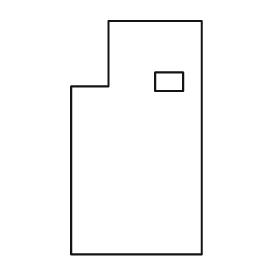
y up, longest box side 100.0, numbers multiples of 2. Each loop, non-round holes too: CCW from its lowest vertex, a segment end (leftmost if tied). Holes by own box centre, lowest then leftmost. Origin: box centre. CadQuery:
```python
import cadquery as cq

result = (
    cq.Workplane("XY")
    .moveTo(-28.0, -50.0)
    .lineTo(28.0, -50.0)
    .lineTo(28.0, 50.0)
    .lineTo(-12.0, 50.0)
    .lineTo(-12.0, 22.0)
    .lineTo(-28.0, 22.0)
    .close()
    .moveTo(8.0, 20.0)
    .lineTo(20.0, 20.0)
    .lineTo(20.0, 28.0)
    .lineTo(8.0, 28.0)
    .close()
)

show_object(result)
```